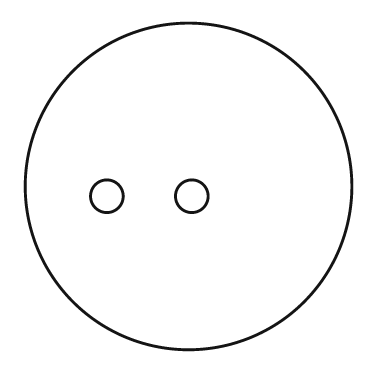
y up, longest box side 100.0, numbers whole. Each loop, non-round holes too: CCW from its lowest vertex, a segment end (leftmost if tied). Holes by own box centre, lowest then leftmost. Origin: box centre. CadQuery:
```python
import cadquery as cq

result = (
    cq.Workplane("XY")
    .moveTo(0.0, 0.0)
    .circle(50.0)
    .moveTo(-25.0, -3.0)
    .circle(5.0)
    .moveTo(1.0, -3.0)
    .circle(5.0)
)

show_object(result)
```